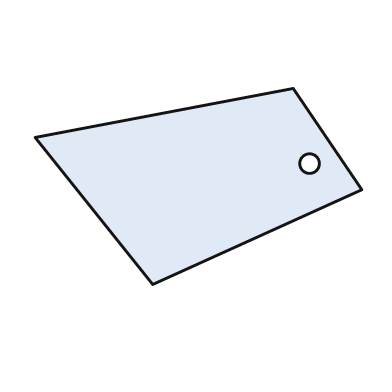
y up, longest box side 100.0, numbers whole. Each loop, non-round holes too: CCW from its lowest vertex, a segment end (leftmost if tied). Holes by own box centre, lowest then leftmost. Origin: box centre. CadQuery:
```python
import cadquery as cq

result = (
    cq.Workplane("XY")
    .moveTo(-14.0, -30.0)
    .lineTo(50.0, -1.0)
    .lineTo(29.0, 30.0)
    .lineTo(-50.0, 15.0)
    .close()
    .moveTo(34.0, 7.0)
    .circle(3.0)
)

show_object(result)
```